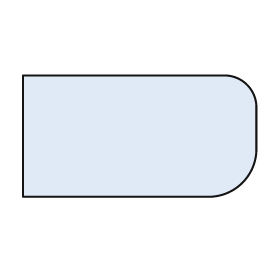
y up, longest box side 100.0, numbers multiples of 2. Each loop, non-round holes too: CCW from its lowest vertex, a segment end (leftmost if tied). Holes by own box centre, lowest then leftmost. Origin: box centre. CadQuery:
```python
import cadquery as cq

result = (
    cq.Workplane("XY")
    .moveTo(-50.0, -26.0)
    .lineTo(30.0, -26.0)
    .threePointArc((44.0, -20.0), (50.0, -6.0))
    .lineTo(50.0, 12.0)
    .threePointArc((46.0, 22.0), (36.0, 26.0))
    .lineTo(-50.0, 26.0)
    .close()
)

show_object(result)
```